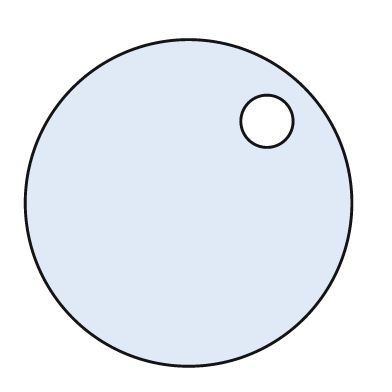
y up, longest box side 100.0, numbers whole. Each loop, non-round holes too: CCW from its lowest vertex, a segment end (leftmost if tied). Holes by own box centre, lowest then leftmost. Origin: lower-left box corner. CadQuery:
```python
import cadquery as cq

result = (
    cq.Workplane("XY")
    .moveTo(50.0, 50.0)
    .circle(50.0)
    .moveTo(74.0, 75.0)
    .circle(8.0)
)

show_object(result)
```